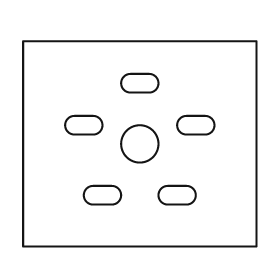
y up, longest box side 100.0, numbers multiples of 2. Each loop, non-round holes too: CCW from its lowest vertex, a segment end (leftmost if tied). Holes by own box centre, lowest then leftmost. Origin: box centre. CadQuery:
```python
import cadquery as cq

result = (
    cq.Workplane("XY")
    .moveTo(-50.0, -44.0)
    .lineTo(50.0, -44.0)
    .lineTo(50.0, 44.0)
    .lineTo(-50.0, 44.0)
    .close()
    .moveTo(-20.0, -26.0)
    .lineTo(-12.0, -26.0)
    .threePointArc((-8.0, -22.0), (-12.0, -18.0))
    .lineTo(-20.0, -18.0)
    .threePointArc((-24.0, -22.0), (-20.0, -26.0))
    .close()
    .moveTo(12.0, -26.0)
    .lineTo(20.0, -26.0)
    .threePointArc((24.0, -22.0), (20.0, -18.0))
    .lineTo(12.0, -18.0)
    .threePointArc((8.0, -22.0), (12.0, -26.0))
    .close()
    .moveTo(0.0, 0.0)
    .circle(8.0)
    .moveTo(-28.0, 4.0)
    .lineTo(-20.0, 4.0)
    .threePointArc((-16.0, 8.0), (-20.0, 12.0))
    .lineTo(-28.0, 12.0)
    .threePointArc((-32.0, 8.0), (-28.0, 4.0))
    .close()
    .moveTo(20.0, 4.0)
    .lineTo(28.0, 4.0)
    .threePointArc((32.0, 8.0), (28.0, 12.0))
    .lineTo(20.0, 12.0)
    .threePointArc((16.0, 8.0), (20.0, 4.0))
    .close()
    .moveTo(-4.0, 22.0)
    .lineTo(4.0, 22.0)
    .threePointArc((8.0, 26.0), (4.0, 30.0))
    .lineTo(-4.0, 30.0)
    .threePointArc((-8.0, 26.0), (-4.0, 22.0))
    .close()
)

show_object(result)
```